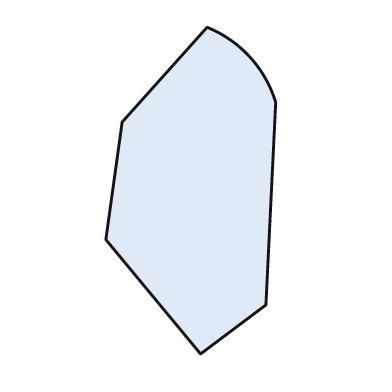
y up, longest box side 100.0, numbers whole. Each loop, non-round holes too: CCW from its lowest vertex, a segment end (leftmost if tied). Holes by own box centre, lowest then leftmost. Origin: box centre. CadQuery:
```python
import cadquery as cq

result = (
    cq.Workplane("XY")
    .moveTo(3.0, -50.0)
    .lineTo(23.0, -35.0)
    .lineTo(26.0, 27.0)
    .threePointArc((18.0, 41.0), (5.0, 50.0))
    .lineTo(-21.0, 21.0)
    .lineTo(-26.0, -15.0)
    .close()
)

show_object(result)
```